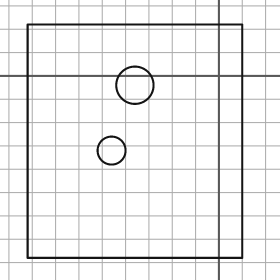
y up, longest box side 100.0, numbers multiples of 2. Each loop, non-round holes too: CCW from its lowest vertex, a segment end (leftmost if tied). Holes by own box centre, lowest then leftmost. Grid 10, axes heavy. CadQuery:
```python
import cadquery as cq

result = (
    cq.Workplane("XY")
    .moveTo(-82.0, -78.0)
    .lineTo(10.0, -78.0)
    .lineTo(10.0, 22.0)
    .lineTo(-82.0, 22.0)
    .close()
    .moveTo(-46.0, -32.0)
    .circle(6.0)
    .moveTo(-36.0, -4.0)
    .circle(8.0)
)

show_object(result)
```